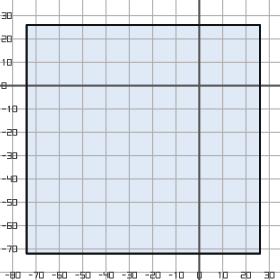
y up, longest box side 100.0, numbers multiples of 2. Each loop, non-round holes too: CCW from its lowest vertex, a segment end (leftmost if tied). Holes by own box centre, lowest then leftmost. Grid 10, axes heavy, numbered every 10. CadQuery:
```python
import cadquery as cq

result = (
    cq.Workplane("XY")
    .moveTo(-74.0, -72.0)
    .lineTo(26.0, -72.0)
    .lineTo(26.0, 26.0)
    .lineTo(-74.0, 26.0)
    .close()
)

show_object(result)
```